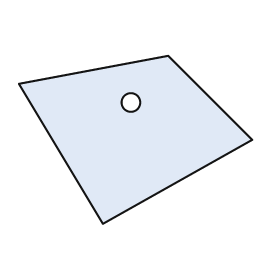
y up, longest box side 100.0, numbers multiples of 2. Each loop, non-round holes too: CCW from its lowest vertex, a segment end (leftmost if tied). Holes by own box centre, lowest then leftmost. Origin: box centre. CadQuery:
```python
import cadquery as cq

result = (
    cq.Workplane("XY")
    .moveTo(-14.0, -36.0)
    .lineTo(50.0, 0.0)
    .lineTo(14.0, 36.0)
    .lineTo(-50.0, 24.0)
    .close()
    .moveTo(-2.0, 16.0)
    .circle(4.0)
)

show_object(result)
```